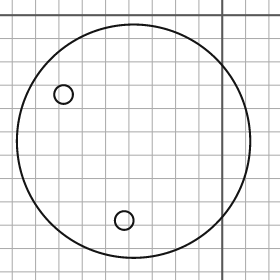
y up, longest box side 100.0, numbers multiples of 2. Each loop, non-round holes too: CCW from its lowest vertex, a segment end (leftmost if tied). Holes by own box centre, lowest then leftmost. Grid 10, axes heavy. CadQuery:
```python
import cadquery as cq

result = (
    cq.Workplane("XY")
    .moveTo(-38.0, -54.0)
    .circle(50.0)
    .moveTo(-42.0, -88.0)
    .circle(4.0)
    .moveTo(-68.0, -34.0)
    .circle(4.0)
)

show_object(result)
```